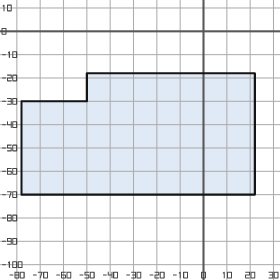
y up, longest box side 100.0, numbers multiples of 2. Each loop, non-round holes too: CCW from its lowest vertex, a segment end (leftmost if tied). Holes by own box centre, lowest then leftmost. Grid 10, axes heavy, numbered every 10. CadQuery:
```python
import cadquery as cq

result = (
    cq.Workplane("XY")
    .moveTo(-78.0, -70.0)
    .lineTo(22.0, -70.0)
    .lineTo(22.0, -18.0)
    .lineTo(-50.0, -18.0)
    .lineTo(-50.0, -30.0)
    .lineTo(-78.0, -30.0)
    .close()
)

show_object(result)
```